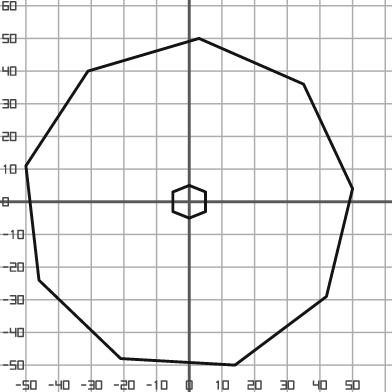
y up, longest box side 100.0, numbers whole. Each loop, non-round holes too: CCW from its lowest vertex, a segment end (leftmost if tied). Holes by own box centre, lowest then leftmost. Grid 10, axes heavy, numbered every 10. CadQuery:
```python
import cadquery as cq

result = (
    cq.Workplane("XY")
    .moveTo(14.0, -50.0)
    .lineTo(42.0, -29.0)
    .lineTo(50.0, 4.0)
    .lineTo(35.0, 36.0)
    .lineTo(3.0, 50.0)
    .lineTo(-31.0, 40.0)
    .lineTo(-50.0, 11.0)
    .lineTo(-46.0, -24.0)
    .lineTo(-21.0, -48.0)
    .close()
    .moveTo(0.0, -5.0)
    .lineTo(5.0, -3.0)
    .lineTo(5.0, 3.0)
    .lineTo(0.0, 5.0)
    .lineTo(-5.0, 3.0)
    .lineTo(-5.0, -3.0)
    .close()
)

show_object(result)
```